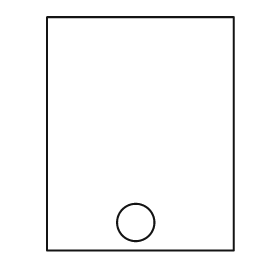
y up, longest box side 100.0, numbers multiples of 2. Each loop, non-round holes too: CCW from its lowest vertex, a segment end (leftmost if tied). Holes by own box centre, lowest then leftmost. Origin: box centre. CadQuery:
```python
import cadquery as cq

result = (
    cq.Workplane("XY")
    .moveTo(-40.0, -50.0)
    .lineTo(40.0, -50.0)
    .lineTo(40.0, 50.0)
    .lineTo(-40.0, 50.0)
    .close()
    .moveTo(-2.0, -38.0)
    .circle(8.0)
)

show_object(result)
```